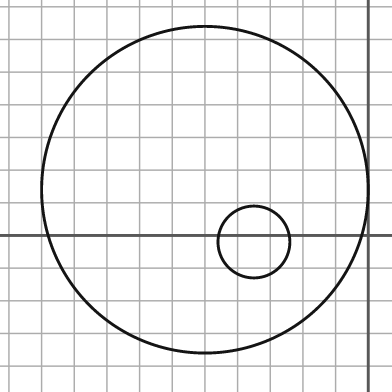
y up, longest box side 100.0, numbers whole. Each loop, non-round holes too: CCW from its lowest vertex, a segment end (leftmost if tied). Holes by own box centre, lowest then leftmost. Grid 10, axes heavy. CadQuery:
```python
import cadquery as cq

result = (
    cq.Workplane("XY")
    .moveTo(-50.0, 14.0)
    .circle(50.0)
    .moveTo(-35.0, -2.0)
    .circle(11.0)
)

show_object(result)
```